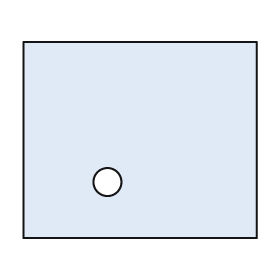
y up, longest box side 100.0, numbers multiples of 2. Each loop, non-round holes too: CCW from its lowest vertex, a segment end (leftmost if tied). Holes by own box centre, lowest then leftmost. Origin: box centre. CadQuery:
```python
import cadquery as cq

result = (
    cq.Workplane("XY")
    .moveTo(-50.0, -42.0)
    .lineTo(50.0, -42.0)
    .lineTo(50.0, 42.0)
    .lineTo(-50.0, 42.0)
    .close()
    .moveTo(-14.0, -18.0)
    .circle(6.0)
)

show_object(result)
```